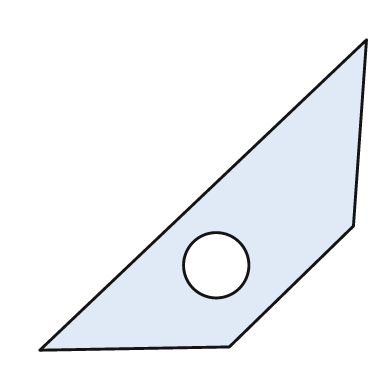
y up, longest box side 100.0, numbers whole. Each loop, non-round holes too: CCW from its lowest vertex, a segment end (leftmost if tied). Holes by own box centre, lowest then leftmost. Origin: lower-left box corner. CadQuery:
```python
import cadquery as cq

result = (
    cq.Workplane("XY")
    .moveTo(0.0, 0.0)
    .lineTo(58.0, 1.0)
    .lineTo(96.0, 38.0)
    .lineTo(100.0, 95.0)
    .close()
    .moveTo(54.0, 26.0)
    .circle(10.0)
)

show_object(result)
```